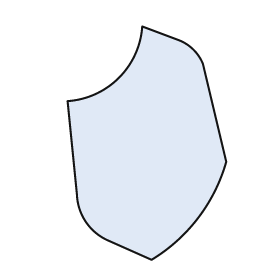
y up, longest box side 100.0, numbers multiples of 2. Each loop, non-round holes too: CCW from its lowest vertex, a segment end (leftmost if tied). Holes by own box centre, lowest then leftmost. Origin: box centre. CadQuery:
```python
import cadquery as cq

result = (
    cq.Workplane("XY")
    .moveTo(2.0, -50.0)
    .threePointArc((22.0, -32.0), (34.0, -8.0))
    .lineTo(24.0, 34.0)
    .threePointArc((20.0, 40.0), (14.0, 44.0))
    .lineTo(-2.0, 50.0)
    .threePointArc((-12.0, 28.0), (-34.0, 18.0))
    .lineTo(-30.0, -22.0)
    .threePointArc((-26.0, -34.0), (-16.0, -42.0))
    .close()
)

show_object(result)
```